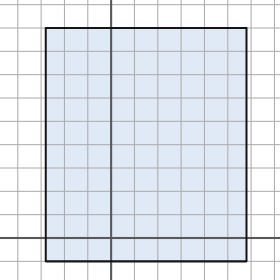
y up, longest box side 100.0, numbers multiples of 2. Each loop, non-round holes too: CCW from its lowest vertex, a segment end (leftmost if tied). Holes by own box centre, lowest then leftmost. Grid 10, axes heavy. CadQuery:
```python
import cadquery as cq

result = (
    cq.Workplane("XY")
    .moveTo(-28.0, -10.0)
    .lineTo(58.0, -10.0)
    .lineTo(58.0, 90.0)
    .lineTo(-28.0, 90.0)
    .close()
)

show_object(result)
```